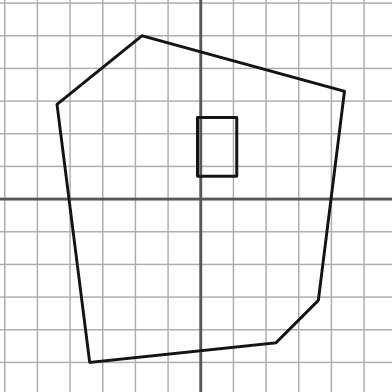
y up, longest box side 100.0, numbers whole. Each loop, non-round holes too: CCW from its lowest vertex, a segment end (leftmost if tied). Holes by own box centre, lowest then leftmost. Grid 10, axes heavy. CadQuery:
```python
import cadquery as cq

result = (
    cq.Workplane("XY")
    .moveTo(-34.0, -50.0)
    .lineTo(23.0, -44.0)
    .lineTo(36.0, -31.0)
    .lineTo(44.0, 33.0)
    .lineTo(-18.0, 50.0)
    .lineTo(-44.0, 29.0)
    .close()
    .moveTo(-1.0, 7.0)
    .lineTo(11.0, 7.0)
    .lineTo(11.0, 25.0)
    .lineTo(-1.0, 25.0)
    .close()
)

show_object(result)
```